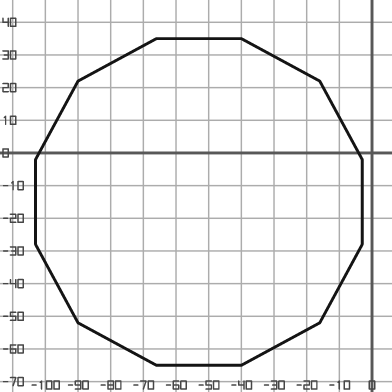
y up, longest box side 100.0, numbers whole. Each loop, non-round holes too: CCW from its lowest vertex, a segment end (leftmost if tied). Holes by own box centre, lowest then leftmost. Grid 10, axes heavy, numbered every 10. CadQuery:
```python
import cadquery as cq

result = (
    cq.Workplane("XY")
    .moveTo(-66.0, -65.0)
    .lineTo(-40.0, -65.0)
    .lineTo(-16.0, -52.0)
    .lineTo(-3.0, -28.0)
    .lineTo(-3.0, -2.0)
    .lineTo(-16.0, 22.0)
    .lineTo(-40.0, 35.0)
    .lineTo(-66.0, 35.0)
    .lineTo(-90.0, 22.0)
    .lineTo(-103.0, -2.0)
    .lineTo(-103.0, -28.0)
    .lineTo(-90.0, -52.0)
    .close()
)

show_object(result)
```